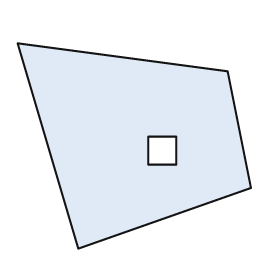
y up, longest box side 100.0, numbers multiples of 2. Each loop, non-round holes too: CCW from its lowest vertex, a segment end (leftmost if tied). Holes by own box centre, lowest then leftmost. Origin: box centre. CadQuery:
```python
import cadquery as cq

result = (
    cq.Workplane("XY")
    .moveTo(-24.0, -44.0)
    .lineTo(50.0, -18.0)
    .lineTo(40.0, 32.0)
    .lineTo(-50.0, 44.0)
    .close()
    .moveTo(6.0, -8.0)
    .lineTo(18.0, -8.0)
    .lineTo(18.0, 4.0)
    .lineTo(6.0, 4.0)
    .close()
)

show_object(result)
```